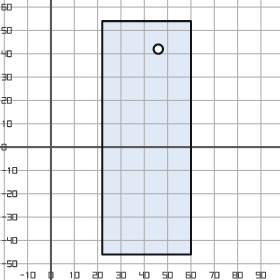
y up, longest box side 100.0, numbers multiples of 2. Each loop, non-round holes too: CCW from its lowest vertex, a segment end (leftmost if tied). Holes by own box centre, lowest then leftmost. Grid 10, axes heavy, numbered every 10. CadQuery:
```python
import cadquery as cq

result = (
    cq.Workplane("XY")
    .moveTo(22.0, -46.0)
    .lineTo(60.0, -46.0)
    .lineTo(60.0, 54.0)
    .lineTo(22.0, 54.0)
    .close()
    .moveTo(46.0, 42.0)
    .circle(2.0)
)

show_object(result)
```